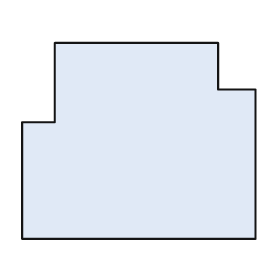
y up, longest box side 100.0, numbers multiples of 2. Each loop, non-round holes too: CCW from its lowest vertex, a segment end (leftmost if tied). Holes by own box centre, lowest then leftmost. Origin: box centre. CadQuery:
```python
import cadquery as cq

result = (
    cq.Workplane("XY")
    .moveTo(-50.0, -42.0)
    .lineTo(50.0, -42.0)
    .lineTo(50.0, 22.0)
    .lineTo(34.0, 22.0)
    .lineTo(34.0, 42.0)
    .lineTo(-36.0, 42.0)
    .lineTo(-36.0, 8.0)
    .lineTo(-50.0, 8.0)
    .close()
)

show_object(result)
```